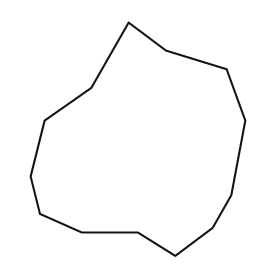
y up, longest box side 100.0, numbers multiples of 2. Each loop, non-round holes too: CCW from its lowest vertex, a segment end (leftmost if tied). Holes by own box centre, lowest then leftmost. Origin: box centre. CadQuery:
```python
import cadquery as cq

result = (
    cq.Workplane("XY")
    .moveTo(16.0, -50.0)
    .lineTo(32.0, -38.0)
    .lineTo(40.0, -24.0)
    .lineTo(46.0, 8.0)
    .lineTo(38.0, 30.0)
    .lineTo(12.0, 38.0)
    .lineTo(-4.0, 50.0)
    .lineTo(-20.0, 22.0)
    .lineTo(-40.0, 8.0)
    .lineTo(-46.0, -16.0)
    .lineTo(-42.0, -32.0)
    .lineTo(-24.0, -40.0)
    .lineTo(0.0, -40.0)
    .close()
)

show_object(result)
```